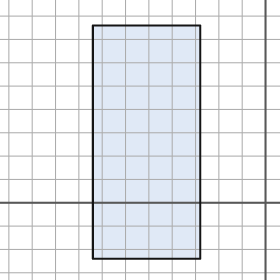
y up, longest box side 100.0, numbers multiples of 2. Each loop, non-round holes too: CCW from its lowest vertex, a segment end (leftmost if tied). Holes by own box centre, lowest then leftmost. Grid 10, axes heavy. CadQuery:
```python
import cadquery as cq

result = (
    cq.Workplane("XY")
    .moveTo(-74.0, -24.0)
    .lineTo(-28.0, -24.0)
    .lineTo(-28.0, 76.0)
    .lineTo(-74.0, 76.0)
    .close()
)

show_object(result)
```